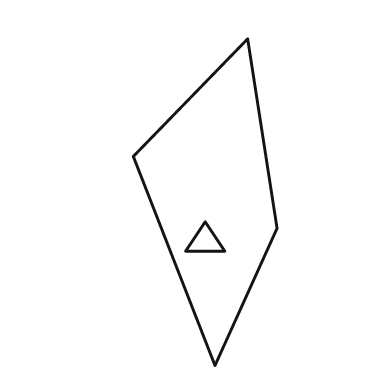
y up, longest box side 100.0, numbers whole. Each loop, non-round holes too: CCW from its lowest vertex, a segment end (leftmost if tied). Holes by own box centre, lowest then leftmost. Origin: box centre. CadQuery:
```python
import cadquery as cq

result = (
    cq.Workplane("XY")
    .moveTo(3.0, -50.0)
    .lineTo(22.0, -8.0)
    .lineTo(13.0, 50.0)
    .lineTo(-22.0, 14.0)
    .close()
    .moveTo(-6.0, -15.0)
    .lineTo(6.0, -15.0)
    .lineTo(0.0, -6.0)
    .close()
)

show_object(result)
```